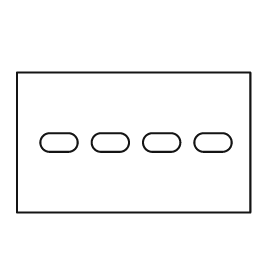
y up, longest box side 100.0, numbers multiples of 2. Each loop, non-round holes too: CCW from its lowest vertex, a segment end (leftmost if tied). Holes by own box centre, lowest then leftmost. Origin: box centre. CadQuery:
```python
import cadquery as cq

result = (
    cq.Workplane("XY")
    .moveTo(-50.0, -30.0)
    .lineTo(50.0, -30.0)
    .lineTo(50.0, 30.0)
    .lineTo(-50.0, 30.0)
    .close()
    .moveTo(-36.0, -4.0)
    .lineTo(-28.0, -4.0)
    .threePointArc((-24.0, 0.0), (-28.0, 4.0))
    .lineTo(-36.0, 4.0)
    .threePointArc((-40.0, 0.0), (-36.0, -4.0))
    .close()
    .moveTo(-14.0, -4.0)
    .lineTo(-6.0, -4.0)
    .threePointArc((-2.0, 0.0), (-6.0, 4.0))
    .lineTo(-14.0, 4.0)
    .threePointArc((-18.0, 0.0), (-14.0, -4.0))
    .close()
    .moveTo(8.0, -4.0)
    .lineTo(16.0, -4.0)
    .threePointArc((20.0, 0.0), (16.0, 4.0))
    .lineTo(8.0, 4.0)
    .threePointArc((4.0, 0.0), (8.0, -4.0))
    .close()
    .moveTo(30.0, -4.0)
    .lineTo(38.0, -4.0)
    .threePointArc((42.0, 0.0), (38.0, 4.0))
    .lineTo(30.0, 4.0)
    .threePointArc((26.0, 0.0), (30.0, -4.0))
    .close()
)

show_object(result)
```